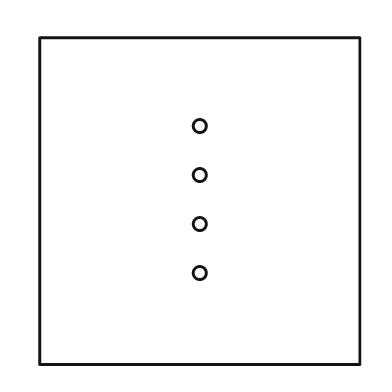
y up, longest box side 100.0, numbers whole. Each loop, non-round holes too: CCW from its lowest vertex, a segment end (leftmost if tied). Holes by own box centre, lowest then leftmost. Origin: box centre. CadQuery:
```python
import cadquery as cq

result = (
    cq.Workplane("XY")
    .moveTo(-49.0, -50.0)
    .lineTo(49.0, -50.0)
    .lineTo(49.0, 50.0)
    .lineTo(-49.0, 50.0)
    .close()
    .moveTo(0.0, -22.0)
    .circle(2.0)
    .moveTo(0.0, -7.0)
    .circle(2.0)
    .moveTo(0.0, 8.0)
    .circle(2.0)
    .moveTo(0.0, 23.0)
    .circle(2.0)
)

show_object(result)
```